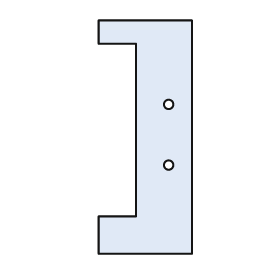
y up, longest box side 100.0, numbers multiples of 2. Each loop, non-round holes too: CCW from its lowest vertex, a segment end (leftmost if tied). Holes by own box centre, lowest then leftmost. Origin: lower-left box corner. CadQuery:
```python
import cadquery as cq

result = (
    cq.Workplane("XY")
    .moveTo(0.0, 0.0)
    .lineTo(40.0, 0.0)
    .lineTo(40.0, 100.0)
    .lineTo(0.0, 100.0)
    .lineTo(0.0, 90.0)
    .lineTo(16.0, 90.0)
    .lineTo(16.0, 16.0)
    .lineTo(0.0, 16.0)
    .close()
    .moveTo(30.0, 38.0)
    .circle(2.0)
    .moveTo(30.0, 64.0)
    .circle(2.0)
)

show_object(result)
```